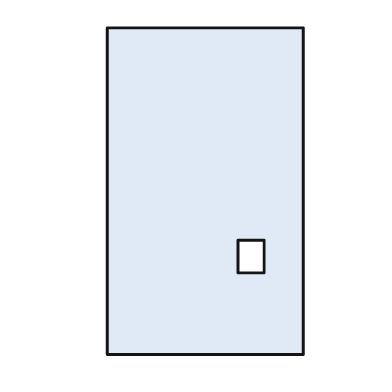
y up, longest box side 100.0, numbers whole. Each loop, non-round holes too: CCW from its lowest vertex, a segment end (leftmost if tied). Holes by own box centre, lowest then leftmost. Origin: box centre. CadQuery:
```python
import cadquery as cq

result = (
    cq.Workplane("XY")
    .moveTo(-30.0, -50.0)
    .lineTo(30.0, -50.0)
    .lineTo(30.0, 50.0)
    .lineTo(-30.0, 50.0)
    .close()
    .moveTo(10.0, -25.0)
    .lineTo(18.0, -25.0)
    .lineTo(18.0, -15.0)
    .lineTo(10.0, -15.0)
    .close()
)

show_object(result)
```